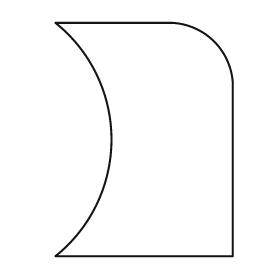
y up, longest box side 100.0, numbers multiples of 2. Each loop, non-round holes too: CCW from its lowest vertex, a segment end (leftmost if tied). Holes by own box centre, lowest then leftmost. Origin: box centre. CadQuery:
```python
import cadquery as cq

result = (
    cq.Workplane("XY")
    .moveTo(-38.0, -50.0)
    .lineTo(38.0, -50.0)
    .lineTo(38.0, 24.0)
    .threePointArc((30.0, 42.0), (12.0, 50.0))
    .lineTo(-38.0, 50.0)
    .threePointArc((-14.0, 0.0), (-38.0, -50.0))
    .close()
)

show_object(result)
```